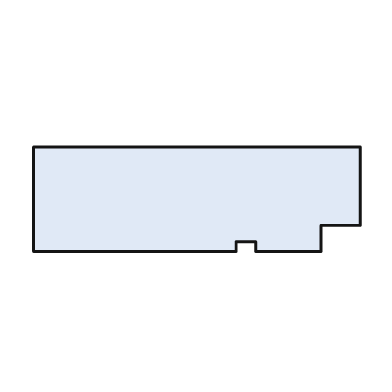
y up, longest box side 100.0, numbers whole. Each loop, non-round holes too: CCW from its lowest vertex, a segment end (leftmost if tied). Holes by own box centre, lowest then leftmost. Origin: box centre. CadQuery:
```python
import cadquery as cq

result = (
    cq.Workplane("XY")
    .moveTo(-50.0, -16.0)
    .lineTo(12.0, -16.0)
    .lineTo(12.0, -13.0)
    .lineTo(18.0, -13.0)
    .lineTo(18.0, -16.0)
    .lineTo(38.0, -16.0)
    .lineTo(38.0, -8.0)
    .lineTo(50.0, -8.0)
    .lineTo(50.0, 16.0)
    .lineTo(-50.0, 16.0)
    .close()
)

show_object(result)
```